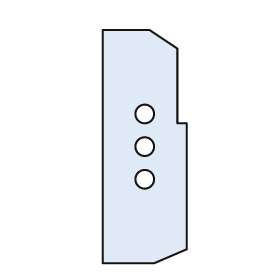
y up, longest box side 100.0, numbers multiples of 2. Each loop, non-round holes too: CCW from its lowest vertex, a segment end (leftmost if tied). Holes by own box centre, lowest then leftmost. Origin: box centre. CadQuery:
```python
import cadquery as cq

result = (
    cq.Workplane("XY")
    .moveTo(-18.0, -50.0)
    .lineTo(4.0, -50.0)
    .lineTo(18.0, -44.0)
    .lineTo(18.0, 10.0)
    .lineTo(14.0, 10.0)
    .lineTo(14.0, 42.0)
    .lineTo(2.0, 50.0)
    .lineTo(-18.0, 50.0)
    .close()
    .moveTo(0.0, -14.0)
    .circle(4.0)
    .moveTo(0.0, 0.0)
    .circle(4.0)
    .moveTo(0.0, 14.0)
    .circle(4.0)
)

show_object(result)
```